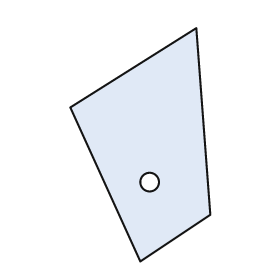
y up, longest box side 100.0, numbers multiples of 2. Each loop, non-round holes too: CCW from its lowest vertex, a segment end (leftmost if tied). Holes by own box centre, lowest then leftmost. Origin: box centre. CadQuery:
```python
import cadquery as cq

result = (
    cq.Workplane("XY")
    .moveTo(0.0, -50.0)
    .lineTo(30.0, -30.0)
    .lineTo(24.0, 50.0)
    .lineTo(-30.0, 16.0)
    .close()
    .moveTo(4.0, -16.0)
    .circle(4.0)
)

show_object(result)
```